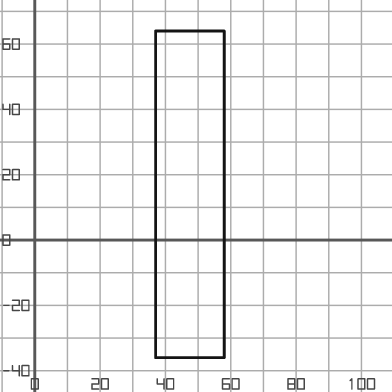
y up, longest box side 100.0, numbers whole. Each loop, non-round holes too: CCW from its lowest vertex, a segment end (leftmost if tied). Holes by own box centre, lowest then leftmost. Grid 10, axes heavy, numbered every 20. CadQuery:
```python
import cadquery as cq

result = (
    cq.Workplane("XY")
    .moveTo(37.0, -36.0)
    .lineTo(58.0, -36.0)
    .lineTo(58.0, 64.0)
    .lineTo(37.0, 64.0)
    .close()
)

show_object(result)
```